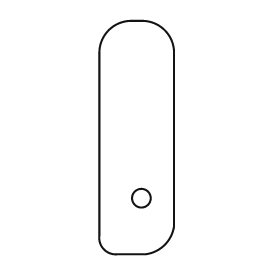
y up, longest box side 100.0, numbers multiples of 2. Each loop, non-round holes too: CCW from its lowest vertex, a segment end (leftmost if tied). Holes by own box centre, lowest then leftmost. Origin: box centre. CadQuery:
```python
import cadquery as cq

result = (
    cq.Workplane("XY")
    .moveTo(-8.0, -50.0)
    .lineTo(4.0, -50.0)
    .threePointArc((12.0, -46.0), (16.0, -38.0))
    .lineTo(16.0, 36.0)
    .threePointArc((12.0, 46.0), (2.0, 50.0))
    .lineTo(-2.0, 50.0)
    .threePointArc((-12.0, 46.0), (-16.0, 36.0))
    .lineTo(-16.0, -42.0)
    .threePointArc((-14.0, -48.0), (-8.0, -50.0))
    .close()
    .moveTo(2.0, -26.0)
    .circle(4.0)
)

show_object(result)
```